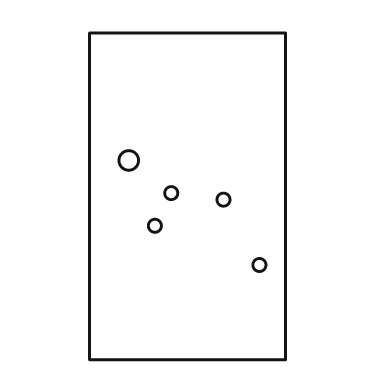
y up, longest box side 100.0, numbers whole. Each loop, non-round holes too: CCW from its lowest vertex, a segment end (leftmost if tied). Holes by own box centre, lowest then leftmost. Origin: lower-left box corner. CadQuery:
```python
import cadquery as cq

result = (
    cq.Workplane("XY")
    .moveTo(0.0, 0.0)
    .lineTo(60.0, 0.0)
    .lineTo(60.0, 100.0)
    .lineTo(0.0, 100.0)
    .close()
    .moveTo(52.0, 29.0)
    .circle(2.0)
    .moveTo(20.0, 41.0)
    .circle(2.0)
    .moveTo(41.0, 49.0)
    .circle(2.0)
    .moveTo(25.0, 51.0)
    .circle(2.0)
    .moveTo(12.0, 61.0)
    .circle(3.0)
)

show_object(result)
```